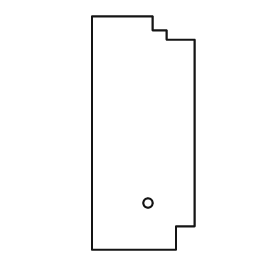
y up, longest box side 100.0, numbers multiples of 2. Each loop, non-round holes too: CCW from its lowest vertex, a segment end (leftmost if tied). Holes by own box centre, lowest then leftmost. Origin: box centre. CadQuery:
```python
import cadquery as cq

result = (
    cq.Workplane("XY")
    .moveTo(-22.0, -50.0)
    .lineTo(14.0, -50.0)
    .lineTo(14.0, -40.0)
    .lineTo(22.0, -40.0)
    .lineTo(22.0, 40.0)
    .lineTo(10.0, 40.0)
    .lineTo(10.0, 44.0)
    .lineTo(4.0, 44.0)
    .lineTo(4.0, 50.0)
    .lineTo(-22.0, 50.0)
    .close()
    .moveTo(2.0, -30.0)
    .circle(2.0)
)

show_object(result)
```